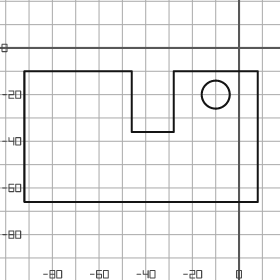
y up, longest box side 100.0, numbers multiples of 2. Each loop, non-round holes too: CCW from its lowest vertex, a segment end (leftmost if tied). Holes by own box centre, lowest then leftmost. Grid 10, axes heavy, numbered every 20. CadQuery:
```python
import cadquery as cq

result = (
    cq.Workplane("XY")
    .moveTo(-92.0, -66.0)
    .lineTo(8.0, -66.0)
    .lineTo(8.0, -10.0)
    .lineTo(-28.0, -10.0)
    .lineTo(-28.0, -36.0)
    .lineTo(-46.0, -36.0)
    .lineTo(-46.0, -10.0)
    .lineTo(-92.0, -10.0)
    .close()
    .moveTo(-10.0, -20.0)
    .circle(6.0)
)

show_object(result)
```